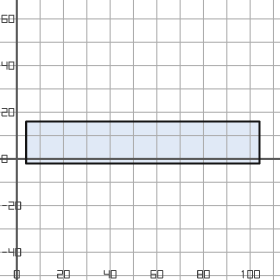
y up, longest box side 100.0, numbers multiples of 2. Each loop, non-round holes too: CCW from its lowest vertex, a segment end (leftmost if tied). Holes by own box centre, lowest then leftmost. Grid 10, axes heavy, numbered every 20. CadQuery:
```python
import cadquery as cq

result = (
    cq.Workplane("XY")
    .moveTo(4.0, -2.0)
    .lineTo(104.0, -2.0)
    .lineTo(104.0, 16.0)
    .lineTo(4.0, 16.0)
    .close()
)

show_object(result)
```